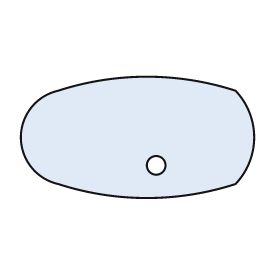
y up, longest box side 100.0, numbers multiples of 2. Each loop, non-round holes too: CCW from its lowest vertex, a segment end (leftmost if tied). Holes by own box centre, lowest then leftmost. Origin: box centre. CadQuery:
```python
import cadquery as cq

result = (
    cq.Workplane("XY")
    .moveTo(-34.0, -20.0)
    .threePointArc((4.0, -26.0), (42.0, -20.0))
    .threePointArc((50.0, 0.0), (42.0, 20.0))
    .threePointArc((4.0, 26.0), (-34.0, 20.0))
    .threePointArc((-50.0, 0.0), (-34.0, -20.0))
    .close()
    .moveTo(8.0, -12.0)
    .circle(4.0)
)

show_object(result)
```